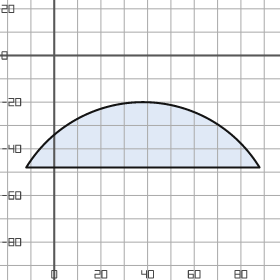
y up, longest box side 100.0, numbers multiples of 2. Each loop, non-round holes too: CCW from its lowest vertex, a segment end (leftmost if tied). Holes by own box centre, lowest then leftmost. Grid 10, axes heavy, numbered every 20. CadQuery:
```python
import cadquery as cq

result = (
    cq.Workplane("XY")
    .moveTo(-12.0, -48.0)
    .lineTo(88.0, -48.0)
    .threePointArc((38.0, -20.0), (-12.0, -48.0))
    .close()
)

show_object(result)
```